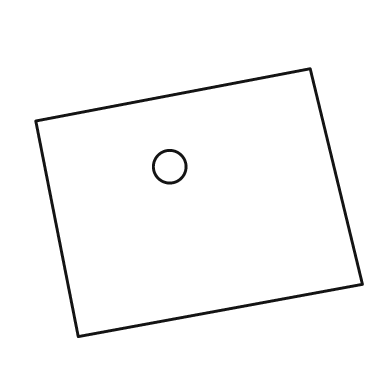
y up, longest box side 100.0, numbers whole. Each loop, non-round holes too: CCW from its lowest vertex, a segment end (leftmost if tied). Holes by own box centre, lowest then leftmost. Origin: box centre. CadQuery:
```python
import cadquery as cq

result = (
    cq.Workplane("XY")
    .moveTo(-37.0, -41.0)
    .lineTo(50.0, -25.0)
    .lineTo(34.0, 41.0)
    .lineTo(-50.0, 25.0)
    .close()
    .moveTo(-9.0, 11.0)
    .circle(5.0)
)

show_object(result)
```